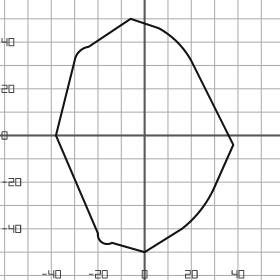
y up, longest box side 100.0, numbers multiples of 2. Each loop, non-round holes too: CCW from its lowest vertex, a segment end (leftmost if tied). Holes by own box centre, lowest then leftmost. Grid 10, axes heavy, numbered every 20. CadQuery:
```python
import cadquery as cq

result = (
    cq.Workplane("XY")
    .moveTo(0.0, -50.0)
    .lineTo(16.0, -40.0)
    .threePointArc((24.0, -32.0), (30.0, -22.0))
    .lineTo(38.0, -4.0)
    .lineTo(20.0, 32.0)
    .threePointArc((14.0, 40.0), (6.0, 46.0))
    .lineTo(-6.0, 50.0)
    .lineTo(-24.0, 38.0)
    .threePointArc((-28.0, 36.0), (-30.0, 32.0))
    .lineTo(-38.0, 0.0)
    .lineTo(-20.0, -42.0)
    .threePointArc((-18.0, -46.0), (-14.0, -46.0))
    .close()
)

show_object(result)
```